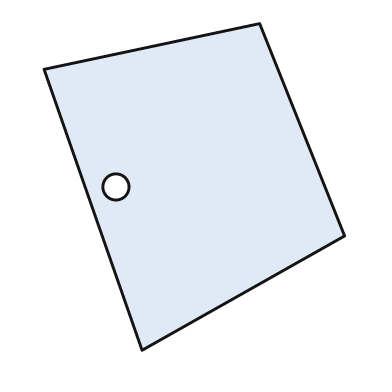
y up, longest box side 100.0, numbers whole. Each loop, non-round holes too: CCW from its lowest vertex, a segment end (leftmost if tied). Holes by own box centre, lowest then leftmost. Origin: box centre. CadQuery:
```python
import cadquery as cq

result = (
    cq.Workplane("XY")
    .moveTo(-16.0, -50.0)
    .lineTo(46.0, -15.0)
    .lineTo(20.0, 50.0)
    .lineTo(-46.0, 36.0)
    .close()
    .moveTo(-24.0, 0.0)
    .circle(4.0)
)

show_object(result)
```